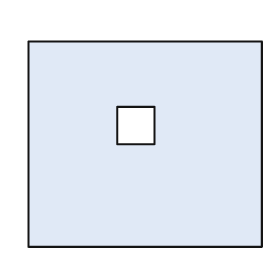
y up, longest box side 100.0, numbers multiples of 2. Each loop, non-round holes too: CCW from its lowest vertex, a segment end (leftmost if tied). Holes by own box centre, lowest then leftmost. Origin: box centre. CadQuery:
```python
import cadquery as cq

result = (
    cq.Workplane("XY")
    .moveTo(-50.0, -44.0)
    .lineTo(50.0, -44.0)
    .lineTo(50.0, 44.0)
    .lineTo(-50.0, 44.0)
    .close()
    .moveTo(-12.0, 0.0)
    .lineTo(4.0, 0.0)
    .lineTo(4.0, 16.0)
    .lineTo(-12.0, 16.0)
    .close()
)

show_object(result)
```